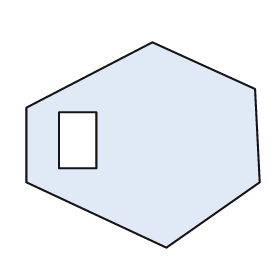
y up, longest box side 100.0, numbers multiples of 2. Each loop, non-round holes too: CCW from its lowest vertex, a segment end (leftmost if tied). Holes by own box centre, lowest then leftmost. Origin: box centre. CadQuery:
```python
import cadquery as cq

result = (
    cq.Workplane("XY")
    .moveTo(10.0, -44.0)
    .lineTo(50.0, -16.0)
    .lineTo(48.0, 24.0)
    .lineTo(4.0, 44.0)
    .lineTo(-50.0, 16.0)
    .lineTo(-50.0, -16.0)
    .close()
    .moveTo(-36.0, -10.0)
    .lineTo(-20.0, -10.0)
    .lineTo(-20.0, 14.0)
    .lineTo(-36.0, 14.0)
    .close()
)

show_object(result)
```